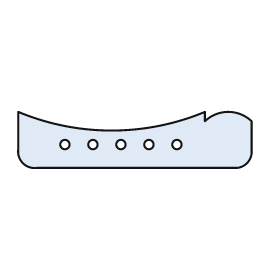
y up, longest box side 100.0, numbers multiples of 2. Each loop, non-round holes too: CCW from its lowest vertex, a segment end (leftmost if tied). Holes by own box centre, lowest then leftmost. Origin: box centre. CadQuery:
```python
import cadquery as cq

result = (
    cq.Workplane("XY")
    .moveTo(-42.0, -12.0)
    .lineTo(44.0, -12.0)
    .threePointArc((48.0, -10.0), (50.0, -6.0))
    .lineTo(50.0, 8.0)
    .threePointArc((40.0, 12.0), (30.0, 8.0))
    .lineTo(30.0, 12.0)
    .threePointArc((-10.0, 4.0), (-50.0, 12.0))
    .lineTo(-50.0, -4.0)
    .threePointArc((-48.0, -10.0), (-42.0, -12.0))
    .close()
    .moveTo(-30.0, -2.0)
    .circle(2.0)
    .moveTo(-18.0, -2.0)
    .circle(2.0)
    .moveTo(-6.0, -2.0)
    .circle(2.0)
    .moveTo(6.0, -2.0)
    .circle(2.0)
    .moveTo(18.0, -2.0)
    .circle(2.0)
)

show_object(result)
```